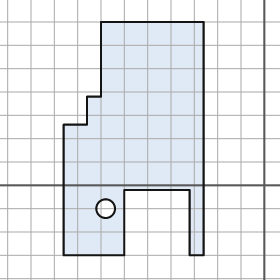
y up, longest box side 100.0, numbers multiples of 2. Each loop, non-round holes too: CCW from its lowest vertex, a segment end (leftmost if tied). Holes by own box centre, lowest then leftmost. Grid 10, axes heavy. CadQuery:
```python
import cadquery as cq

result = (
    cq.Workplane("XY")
    .moveTo(-86.0, -30.0)
    .lineTo(-60.0, -30.0)
    .lineTo(-60.0, -2.0)
    .lineTo(-32.0, -2.0)
    .lineTo(-32.0, -30.0)
    .lineTo(-26.0, -30.0)
    .lineTo(-26.0, 70.0)
    .lineTo(-70.0, 70.0)
    .lineTo(-70.0, 38.0)
    .lineTo(-76.0, 38.0)
    .lineTo(-76.0, 26.0)
    .lineTo(-86.0, 26.0)
    .close()
    .moveTo(-68.0, -10.0)
    .circle(4.0)
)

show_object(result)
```